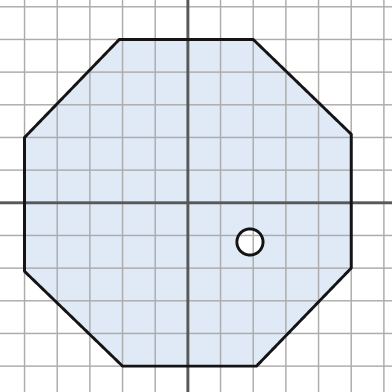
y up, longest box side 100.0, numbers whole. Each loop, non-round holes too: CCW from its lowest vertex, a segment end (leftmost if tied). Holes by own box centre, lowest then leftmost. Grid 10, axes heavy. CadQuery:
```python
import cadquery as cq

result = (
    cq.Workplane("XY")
    .moveTo(-20.0, -50.0)
    .lineTo(21.0, -50.0)
    .lineTo(50.0, -20.0)
    .lineTo(50.0, 21.0)
    .lineTo(20.0, 50.0)
    .lineTo(-21.0, 50.0)
    .lineTo(-50.0, 20.0)
    .lineTo(-50.0, -21.0)
    .close()
    .moveTo(19.0, -12.0)
    .circle(4.0)
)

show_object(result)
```